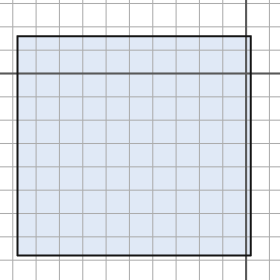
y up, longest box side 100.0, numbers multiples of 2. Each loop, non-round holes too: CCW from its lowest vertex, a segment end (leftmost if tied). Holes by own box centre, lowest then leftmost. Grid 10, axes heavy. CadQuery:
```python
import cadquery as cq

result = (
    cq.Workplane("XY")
    .moveTo(-98.0, -78.0)
    .lineTo(2.0, -78.0)
    .lineTo(2.0, 16.0)
    .lineTo(-98.0, 16.0)
    .close()
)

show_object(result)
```